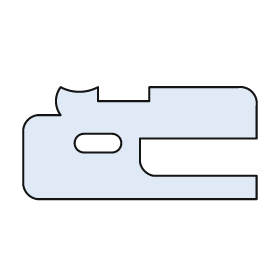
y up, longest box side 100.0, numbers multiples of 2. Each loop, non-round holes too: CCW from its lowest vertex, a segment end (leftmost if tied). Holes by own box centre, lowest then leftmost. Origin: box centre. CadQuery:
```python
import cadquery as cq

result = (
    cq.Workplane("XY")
    .moveTo(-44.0, -24.0)
    .lineTo(50.0, -24.0)
    .lineTo(50.0, -14.0)
    .lineTo(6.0, -14.0)
    .threePointArc((2.0, -12.0), (0.0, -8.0))
    .lineTo(0.0, 2.0)
    .lineTo(50.0, 2.0)
    .lineTo(50.0, 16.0)
    .threePointArc((48.0, 22.0), (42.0, 24.0))
    .lineTo(4.0, 24.0)
    .lineTo(4.0, 18.0)
    .lineTo(-18.0, 18.0)
    .lineTo(-18.0, 24.0)
    .threePointArc((-26.0, 22.0), (-34.0, 24.0))
    .threePointArc((-36.0, 18.0), (-34.0, 12.0))
    .lineTo(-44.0, 12.0)
    .threePointArc((-48.0, 10.0), (-50.0, 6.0))
    .lineTo(-50.0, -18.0)
    .threePointArc((-48.0, -22.0), (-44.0, -24.0))
    .close()
    .moveTo(-24.0, -4.0)
    .lineTo(-12.0, -4.0)
    .threePointArc((-8.0, 0.0), (-12.0, 4.0))
    .lineTo(-24.0, 4.0)
    .threePointArc((-28.0, 0.0), (-24.0, -4.0))
    .close()
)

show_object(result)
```